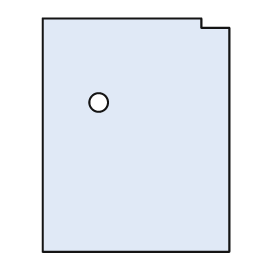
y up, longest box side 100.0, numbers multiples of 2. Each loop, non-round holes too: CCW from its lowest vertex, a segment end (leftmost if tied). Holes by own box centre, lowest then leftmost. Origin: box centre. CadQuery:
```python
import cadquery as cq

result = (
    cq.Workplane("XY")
    .moveTo(-40.0, -50.0)
    .lineTo(40.0, -50.0)
    .lineTo(40.0, 46.0)
    .lineTo(28.0, 46.0)
    .lineTo(28.0, 50.0)
    .lineTo(-40.0, 50.0)
    .close()
    .moveTo(-16.0, 14.0)
    .circle(4.0)
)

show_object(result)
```